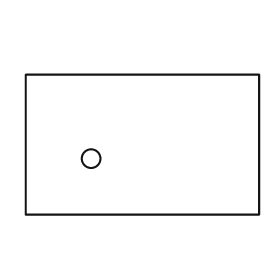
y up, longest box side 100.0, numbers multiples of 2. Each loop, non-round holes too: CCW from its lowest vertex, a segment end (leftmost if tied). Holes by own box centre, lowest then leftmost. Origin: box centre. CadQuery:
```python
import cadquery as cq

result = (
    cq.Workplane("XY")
    .moveTo(-50.0, -30.0)
    .lineTo(50.0, -30.0)
    .lineTo(50.0, 30.0)
    .lineTo(-50.0, 30.0)
    .close()
    .moveTo(-22.0, -6.0)
    .circle(4.0)
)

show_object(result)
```